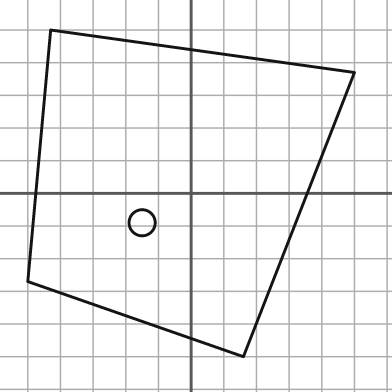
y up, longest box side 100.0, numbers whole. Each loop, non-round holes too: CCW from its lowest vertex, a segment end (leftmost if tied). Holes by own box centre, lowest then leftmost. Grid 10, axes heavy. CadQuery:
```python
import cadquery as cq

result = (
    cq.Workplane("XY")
    .moveTo(16.0, -50.0)
    .lineTo(50.0, 37.0)
    .lineTo(-43.0, 50.0)
    .lineTo(-50.0, -27.0)
    .close()
    .moveTo(-15.0, -9.0)
    .circle(4.0)
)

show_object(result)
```